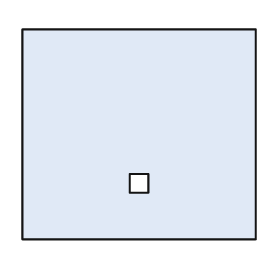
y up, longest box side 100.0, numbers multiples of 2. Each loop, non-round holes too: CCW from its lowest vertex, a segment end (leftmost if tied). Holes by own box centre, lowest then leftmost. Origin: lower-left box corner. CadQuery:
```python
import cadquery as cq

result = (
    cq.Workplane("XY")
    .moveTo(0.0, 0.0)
    .lineTo(100.0, 0.0)
    .lineTo(100.0, 90.0)
    .lineTo(0.0, 90.0)
    .close()
    .moveTo(46.0, 20.0)
    .lineTo(54.0, 20.0)
    .lineTo(54.0, 28.0)
    .lineTo(46.0, 28.0)
    .close()
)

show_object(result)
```